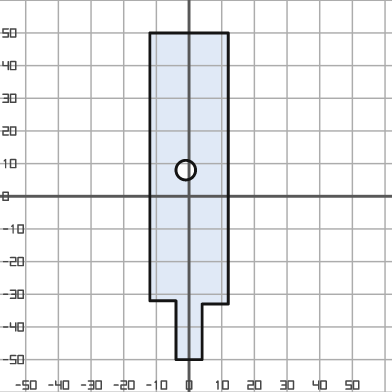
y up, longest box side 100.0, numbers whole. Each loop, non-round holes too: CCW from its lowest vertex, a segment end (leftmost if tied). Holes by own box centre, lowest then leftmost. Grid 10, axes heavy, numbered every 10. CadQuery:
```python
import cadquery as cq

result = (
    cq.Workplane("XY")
    .moveTo(-4.0, -50.0)
    .lineTo(4.0, -50.0)
    .lineTo(4.0, -33.0)
    .lineTo(12.0, -33.0)
    .lineTo(12.0, 50.0)
    .lineTo(-12.0, 50.0)
    .lineTo(-12.0, -32.0)
    .lineTo(-4.0, -32.0)
    .close()
    .moveTo(-1.0, 8.0)
    .circle(3.0)
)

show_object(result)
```